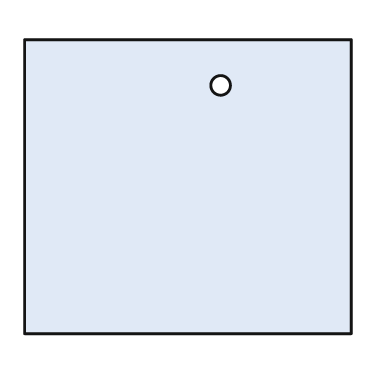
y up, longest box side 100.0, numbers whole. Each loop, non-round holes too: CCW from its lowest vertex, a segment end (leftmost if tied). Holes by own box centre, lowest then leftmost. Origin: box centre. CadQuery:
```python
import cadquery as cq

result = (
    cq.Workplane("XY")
    .moveTo(-50.0, -45.0)
    .lineTo(50.0, -45.0)
    .lineTo(50.0, 45.0)
    .lineTo(-50.0, 45.0)
    .close()
    .moveTo(10.0, 31.0)
    .circle(3.0)
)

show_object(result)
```